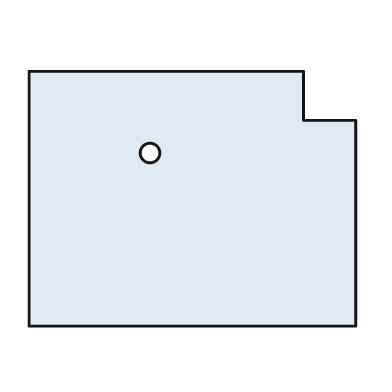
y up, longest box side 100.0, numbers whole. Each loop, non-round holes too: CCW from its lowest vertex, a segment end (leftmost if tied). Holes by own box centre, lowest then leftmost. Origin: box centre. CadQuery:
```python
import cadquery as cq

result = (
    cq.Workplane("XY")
    .moveTo(-50.0, -39.0)
    .lineTo(50.0, -39.0)
    .lineTo(50.0, 24.0)
    .lineTo(34.0, 24.0)
    .lineTo(34.0, 39.0)
    .lineTo(-50.0, 39.0)
    .close()
    .moveTo(-13.0, 14.0)
    .circle(3.0)
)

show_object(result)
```